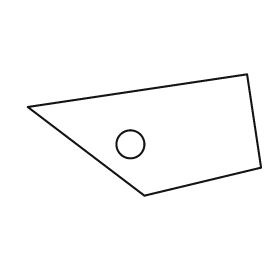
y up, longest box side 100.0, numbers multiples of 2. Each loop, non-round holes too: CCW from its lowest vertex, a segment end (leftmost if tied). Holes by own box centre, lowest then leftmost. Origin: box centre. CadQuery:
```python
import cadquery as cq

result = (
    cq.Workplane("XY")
    .moveTo(0.0, -26.0)
    .lineTo(50.0, -14.0)
    .lineTo(44.0, 26.0)
    .lineTo(-50.0, 12.0)
    .close()
    .moveTo(-6.0, -4.0)
    .circle(6.0)
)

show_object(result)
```